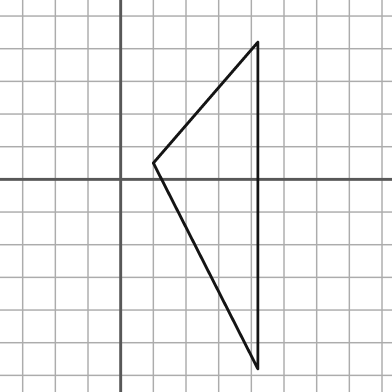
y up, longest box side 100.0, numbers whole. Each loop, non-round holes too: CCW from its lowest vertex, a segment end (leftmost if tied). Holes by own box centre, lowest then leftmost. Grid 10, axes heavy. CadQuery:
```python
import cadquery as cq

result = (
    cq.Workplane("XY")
    .moveTo(42.0, -58.0)
    .lineTo(42.0, 42.0)
    .lineTo(10.0, 5.0)
    .close()
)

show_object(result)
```